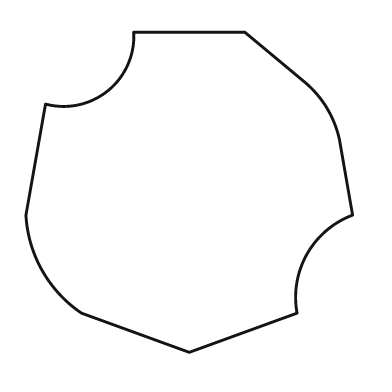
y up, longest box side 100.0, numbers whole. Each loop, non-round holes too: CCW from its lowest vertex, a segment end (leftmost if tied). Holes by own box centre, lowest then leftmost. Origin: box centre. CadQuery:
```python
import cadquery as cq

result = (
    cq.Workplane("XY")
    .moveTo(0.0, -49.0)
    .lineTo(33.0, -37.0)
    .threePointArc((36.0, -19.0), (50.0, -7.0))
    .lineTo(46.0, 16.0)
    .threePointArc((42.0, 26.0), (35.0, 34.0))
    .lineTo(17.0, 49.0)
    .lineTo(-17.0, 49.0)
    .threePointArc((-25.0, 31.0), (-44.0, 27.0))
    .lineTo(-50.0, -7.0)
    .threePointArc((-45.0, -24.0), (-33.0, -37.0))
    .close()
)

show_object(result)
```